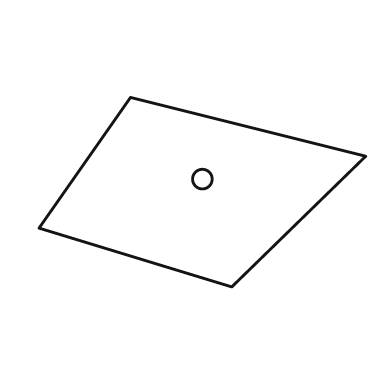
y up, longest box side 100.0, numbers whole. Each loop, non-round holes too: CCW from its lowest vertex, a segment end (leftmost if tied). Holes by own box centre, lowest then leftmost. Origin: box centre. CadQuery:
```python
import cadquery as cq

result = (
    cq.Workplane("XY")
    .moveTo(9.0, -29.0)
    .lineTo(50.0, 11.0)
    .lineTo(-22.0, 29.0)
    .lineTo(-50.0, -11.0)
    .close()
    .moveTo(0.0, 4.0)
    .circle(3.0)
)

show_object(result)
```